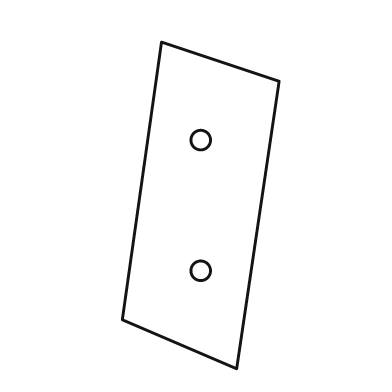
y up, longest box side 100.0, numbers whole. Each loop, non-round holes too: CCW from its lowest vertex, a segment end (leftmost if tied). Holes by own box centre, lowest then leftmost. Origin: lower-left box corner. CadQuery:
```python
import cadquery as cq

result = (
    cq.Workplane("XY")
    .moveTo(35.0, 0.0)
    .lineTo(48.0, 88.0)
    .lineTo(12.0, 100.0)
    .lineTo(0.0, 15.0)
    .close()
    .moveTo(24.0, 30.0)
    .circle(3.0)
    .moveTo(24.0, 70.0)
    .circle(3.0)
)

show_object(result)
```